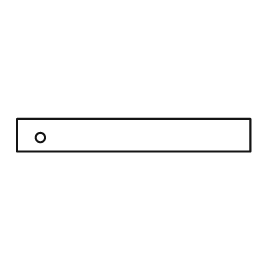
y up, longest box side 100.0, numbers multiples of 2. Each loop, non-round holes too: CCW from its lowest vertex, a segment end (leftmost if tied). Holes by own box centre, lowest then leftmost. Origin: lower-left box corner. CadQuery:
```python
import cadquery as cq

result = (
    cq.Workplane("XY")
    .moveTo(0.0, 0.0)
    .lineTo(100.0, 0.0)
    .lineTo(100.0, 14.0)
    .lineTo(0.0, 14.0)
    .close()
    .moveTo(10.0, 6.0)
    .circle(2.0)
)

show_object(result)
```